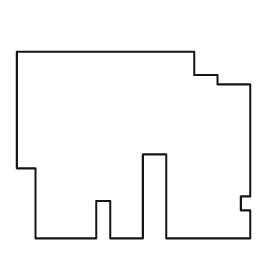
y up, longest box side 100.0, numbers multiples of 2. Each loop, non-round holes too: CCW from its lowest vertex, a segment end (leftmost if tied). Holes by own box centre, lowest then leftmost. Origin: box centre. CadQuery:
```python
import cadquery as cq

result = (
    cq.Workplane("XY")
    .moveTo(-42.0, -40.0)
    .lineTo(-16.0, -40.0)
    .lineTo(-16.0, -24.0)
    .lineTo(-10.0, -24.0)
    .lineTo(-10.0, -40.0)
    .lineTo(4.0, -40.0)
    .lineTo(4.0, -4.0)
    .lineTo(14.0, -4.0)
    .lineTo(14.0, -40.0)
    .lineTo(50.0, -40.0)
    .lineTo(50.0, -28.0)
    .lineTo(46.0, -28.0)
    .lineTo(46.0, -22.0)
    .lineTo(50.0, -22.0)
    .lineTo(50.0, 26.0)
    .lineTo(36.0, 26.0)
    .lineTo(36.0, 30.0)
    .lineTo(26.0, 30.0)
    .lineTo(26.0, 40.0)
    .lineTo(-50.0, 40.0)
    .lineTo(-50.0, -10.0)
    .lineTo(-42.0, -10.0)
    .close()
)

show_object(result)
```